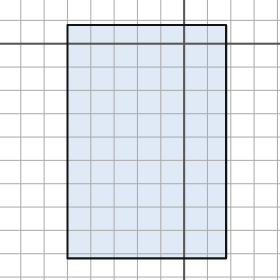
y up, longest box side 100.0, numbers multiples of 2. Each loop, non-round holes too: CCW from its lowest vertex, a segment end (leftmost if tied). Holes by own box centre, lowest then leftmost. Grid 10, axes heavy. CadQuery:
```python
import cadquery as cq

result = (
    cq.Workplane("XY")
    .moveTo(-50.0, -92.0)
    .lineTo(18.0, -92.0)
    .lineTo(18.0, 8.0)
    .lineTo(-50.0, 8.0)
    .close()
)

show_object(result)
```